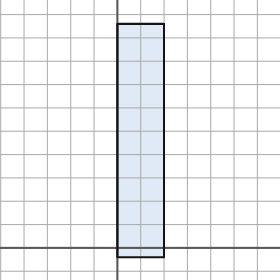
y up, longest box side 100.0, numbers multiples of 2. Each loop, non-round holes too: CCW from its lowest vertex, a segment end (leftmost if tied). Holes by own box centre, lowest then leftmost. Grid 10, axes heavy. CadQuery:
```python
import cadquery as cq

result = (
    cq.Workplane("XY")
    .moveTo(0.0, -4.0)
    .lineTo(20.0, -4.0)
    .lineTo(20.0, 96.0)
    .lineTo(0.0, 96.0)
    .close()
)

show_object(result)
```